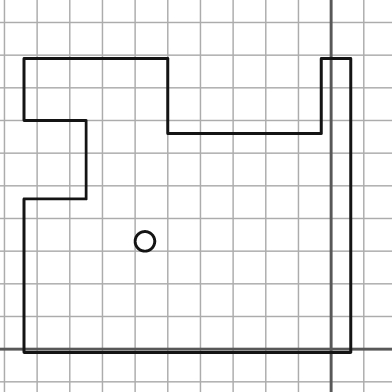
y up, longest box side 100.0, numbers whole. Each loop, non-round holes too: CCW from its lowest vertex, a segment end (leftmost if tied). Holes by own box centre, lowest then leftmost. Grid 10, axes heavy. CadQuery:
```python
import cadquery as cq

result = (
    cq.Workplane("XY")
    .moveTo(-94.0, -1.0)
    .lineTo(6.0, -1.0)
    .lineTo(6.0, 89.0)
    .lineTo(-3.0, 89.0)
    .lineTo(-3.0, 66.0)
    .lineTo(-50.0, 66.0)
    .lineTo(-50.0, 89.0)
    .lineTo(-94.0, 89.0)
    .lineTo(-94.0, 70.0)
    .lineTo(-75.0, 70.0)
    .lineTo(-75.0, 46.0)
    .lineTo(-94.0, 46.0)
    .close()
    .moveTo(-57.0, 33.0)
    .circle(3.0)
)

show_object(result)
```